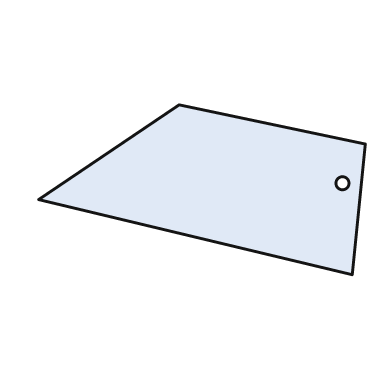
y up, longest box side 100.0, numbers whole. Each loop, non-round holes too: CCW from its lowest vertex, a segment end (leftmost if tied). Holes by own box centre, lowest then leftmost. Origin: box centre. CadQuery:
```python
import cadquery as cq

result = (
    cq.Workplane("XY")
    .moveTo(46.0, -26.0)
    .lineTo(50.0, 14.0)
    .lineTo(-7.0, 26.0)
    .lineTo(-50.0, -3.0)
    .close()
    .moveTo(43.0, 2.0)
    .circle(2.0)
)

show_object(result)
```